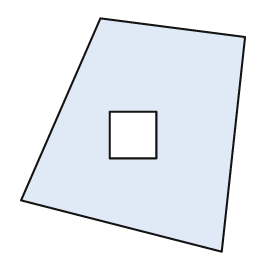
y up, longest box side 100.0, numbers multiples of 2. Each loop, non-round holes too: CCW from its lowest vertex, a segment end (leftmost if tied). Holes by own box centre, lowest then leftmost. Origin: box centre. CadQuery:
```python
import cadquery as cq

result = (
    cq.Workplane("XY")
    .moveTo(38.0, -50.0)
    .lineTo(48.0, 42.0)
    .lineTo(-14.0, 50.0)
    .lineTo(-48.0, -28.0)
    .close()
    .moveTo(-10.0, -10.0)
    .lineTo(10.0, -10.0)
    .lineTo(10.0, 10.0)
    .lineTo(-10.0, 10.0)
    .close()
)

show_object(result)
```